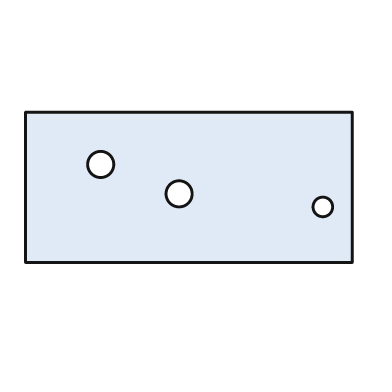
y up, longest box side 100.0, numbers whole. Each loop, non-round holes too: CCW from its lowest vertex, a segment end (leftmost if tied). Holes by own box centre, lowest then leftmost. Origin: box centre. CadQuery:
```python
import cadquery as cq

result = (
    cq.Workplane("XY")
    .moveTo(-50.0, -23.0)
    .lineTo(50.0, -23.0)
    .lineTo(50.0, 23.0)
    .lineTo(-50.0, 23.0)
    .close()
    .moveTo(41.0, -6.0)
    .circle(3.0)
    .moveTo(-3.0, -2.0)
    .circle(4.0)
    .moveTo(-27.0, 7.0)
    .circle(4.0)
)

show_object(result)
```